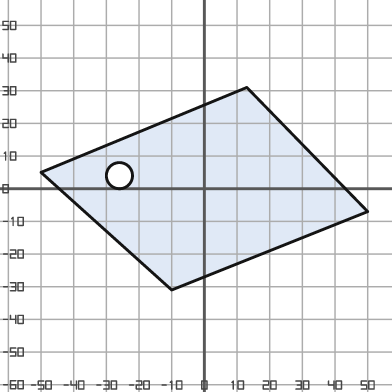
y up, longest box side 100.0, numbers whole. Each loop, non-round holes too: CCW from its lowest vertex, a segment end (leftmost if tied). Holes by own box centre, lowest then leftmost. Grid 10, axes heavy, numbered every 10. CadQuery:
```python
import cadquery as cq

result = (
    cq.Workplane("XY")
    .moveTo(-10.0, -31.0)
    .lineTo(50.0, -7.0)
    .lineTo(13.0, 31.0)
    .lineTo(-50.0, 5.0)
    .close()
    .moveTo(-26.0, 4.0)
    .circle(4.0)
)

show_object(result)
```